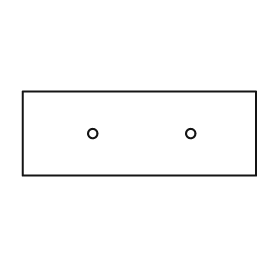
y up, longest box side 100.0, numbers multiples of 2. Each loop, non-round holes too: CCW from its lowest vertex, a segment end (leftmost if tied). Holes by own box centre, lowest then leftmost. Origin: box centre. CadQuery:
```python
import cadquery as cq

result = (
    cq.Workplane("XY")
    .moveTo(-50.0, -18.0)
    .lineTo(50.0, -18.0)
    .lineTo(50.0, 18.0)
    .lineTo(-50.0, 18.0)
    .close()
    .moveTo(-20.0, 0.0)
    .circle(2.0)
    .moveTo(22.0, 0.0)
    .circle(2.0)
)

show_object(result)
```